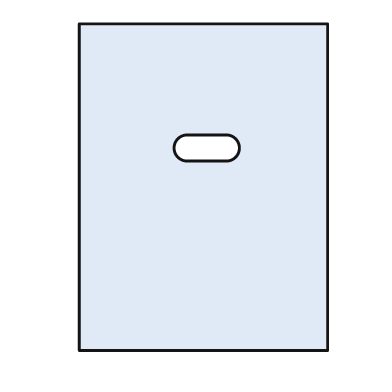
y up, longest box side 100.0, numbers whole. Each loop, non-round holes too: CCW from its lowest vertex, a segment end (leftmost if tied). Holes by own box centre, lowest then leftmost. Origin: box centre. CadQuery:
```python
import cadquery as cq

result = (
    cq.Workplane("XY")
    .moveTo(-38.0, -50.0)
    .lineTo(38.0, -50.0)
    .lineTo(38.0, 50.0)
    .lineTo(-38.0, 50.0)
    .close()
    .moveTo(-5.0, 8.0)
    .lineTo(7.0, 8.0)
    .threePointArc((11.0, 12.0), (7.0, 16.0))
    .lineTo(-5.0, 16.0)
    .threePointArc((-9.0, 12.0), (-5.0, 8.0))
    .close()
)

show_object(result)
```